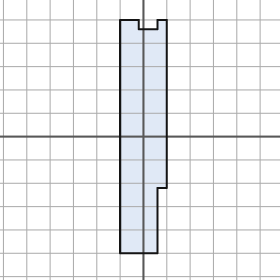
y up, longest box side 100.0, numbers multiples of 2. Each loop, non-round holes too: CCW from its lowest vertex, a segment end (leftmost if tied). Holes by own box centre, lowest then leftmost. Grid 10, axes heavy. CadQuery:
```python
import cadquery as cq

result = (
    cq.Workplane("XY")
    .moveTo(-10.0, -50.0)
    .lineTo(6.0, -50.0)
    .lineTo(6.0, -22.0)
    .lineTo(10.0, -22.0)
    .lineTo(10.0, 50.0)
    .lineTo(6.0, 50.0)
    .lineTo(6.0, 46.0)
    .lineTo(-2.0, 46.0)
    .lineTo(-2.0, 50.0)
    .lineTo(-10.0, 50.0)
    .close()
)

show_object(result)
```